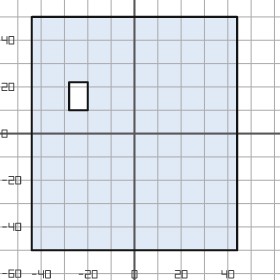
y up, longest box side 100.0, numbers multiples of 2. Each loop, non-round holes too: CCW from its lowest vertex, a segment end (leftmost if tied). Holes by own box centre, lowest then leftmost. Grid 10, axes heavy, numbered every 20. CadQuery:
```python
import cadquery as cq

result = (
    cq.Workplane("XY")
    .moveTo(-44.0, -50.0)
    .lineTo(44.0, -50.0)
    .lineTo(44.0, 50.0)
    .lineTo(-44.0, 50.0)
    .close()
    .moveTo(-28.0, 10.0)
    .lineTo(-20.0, 10.0)
    .lineTo(-20.0, 22.0)
    .lineTo(-28.0, 22.0)
    .close()
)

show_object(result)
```